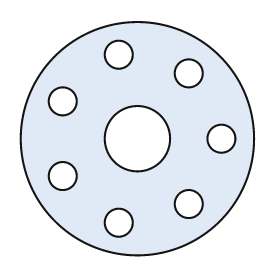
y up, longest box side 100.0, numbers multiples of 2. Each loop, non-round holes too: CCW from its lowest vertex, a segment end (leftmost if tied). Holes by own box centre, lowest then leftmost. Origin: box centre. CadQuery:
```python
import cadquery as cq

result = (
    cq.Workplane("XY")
    .moveTo(0.0, 0.0)
    .circle(50.0)
    .moveTo(-8.0, -36.0)
    .circle(6.0)
    .moveTo(22.0, -28.0)
    .circle(6.0)
    .moveTo(-32.0, -16.0)
    .circle(6.0)
    .moveTo(0.0, 0.0)
    .circle(14.0)
    .moveTo(36.0, 0.0)
    .circle(6.0)
    .moveTo(-32.0, 16.0)
    .circle(6.0)
    .moveTo(22.0, 28.0)
    .circle(6.0)
    .moveTo(-8.0, 36.0)
    .circle(6.0)
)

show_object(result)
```